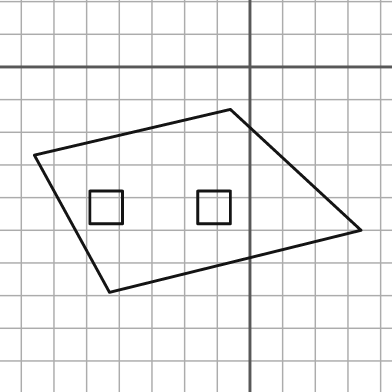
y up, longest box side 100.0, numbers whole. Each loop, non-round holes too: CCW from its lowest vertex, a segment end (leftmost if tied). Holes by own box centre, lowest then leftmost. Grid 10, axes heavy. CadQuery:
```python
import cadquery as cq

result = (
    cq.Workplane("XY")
    .moveTo(-43.0, -69.0)
    .lineTo(34.0, -50.0)
    .lineTo(-6.0, -13.0)
    .lineTo(-66.0, -27.0)
    .close()
    .moveTo(-49.0, -48.0)
    .lineTo(-39.0, -48.0)
    .lineTo(-39.0, -38.0)
    .lineTo(-49.0, -38.0)
    .close()
    .moveTo(-16.0, -48.0)
    .lineTo(-6.0, -48.0)
    .lineTo(-6.0, -38.0)
    .lineTo(-16.0, -38.0)
    .close()
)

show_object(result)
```